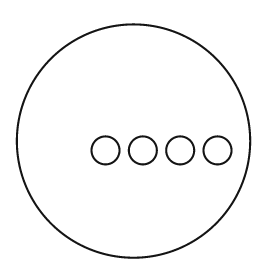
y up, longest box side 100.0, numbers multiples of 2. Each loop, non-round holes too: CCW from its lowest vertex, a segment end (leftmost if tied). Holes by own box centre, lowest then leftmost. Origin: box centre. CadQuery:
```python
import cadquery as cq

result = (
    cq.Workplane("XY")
    .moveTo(0.0, 0.0)
    .circle(50.0)
    .moveTo(-12.0, -4.0)
    .circle(6.0)
    .moveTo(4.0, -4.0)
    .circle(6.0)
    .moveTo(20.0, -4.0)
    .circle(6.0)
    .moveTo(36.0, -4.0)
    .circle(6.0)
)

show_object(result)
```